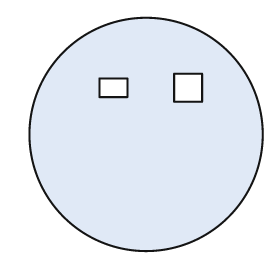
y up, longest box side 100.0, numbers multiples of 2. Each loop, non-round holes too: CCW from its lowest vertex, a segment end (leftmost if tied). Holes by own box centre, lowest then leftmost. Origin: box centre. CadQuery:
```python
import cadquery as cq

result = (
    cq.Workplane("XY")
    .moveTo(0.0, 0.0)
    .circle(50.0)
    .moveTo(-20.0, 16.0)
    .lineTo(-8.0, 16.0)
    .lineTo(-8.0, 24.0)
    .lineTo(-20.0, 24.0)
    .close()
    .moveTo(12.0, 14.0)
    .lineTo(24.0, 14.0)
    .lineTo(24.0, 26.0)
    .lineTo(12.0, 26.0)
    .close()
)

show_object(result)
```